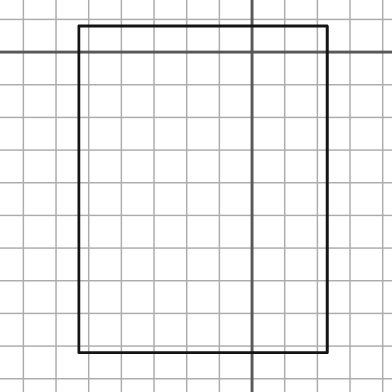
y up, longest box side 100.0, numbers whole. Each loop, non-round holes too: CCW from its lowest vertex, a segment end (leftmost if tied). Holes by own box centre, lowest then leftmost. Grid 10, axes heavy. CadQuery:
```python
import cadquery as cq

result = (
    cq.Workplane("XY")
    .moveTo(-53.0, -92.0)
    .lineTo(23.0, -92.0)
    .lineTo(23.0, 8.0)
    .lineTo(-53.0, 8.0)
    .close()
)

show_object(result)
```